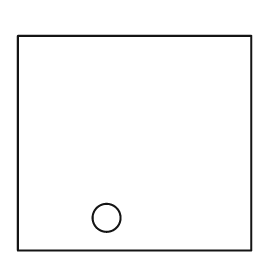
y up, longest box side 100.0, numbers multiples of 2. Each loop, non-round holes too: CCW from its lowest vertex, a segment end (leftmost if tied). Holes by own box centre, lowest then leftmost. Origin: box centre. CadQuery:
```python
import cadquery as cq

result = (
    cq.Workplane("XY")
    .moveTo(-50.0, -46.0)
    .lineTo(50.0, -46.0)
    .lineTo(50.0, 46.0)
    .lineTo(-50.0, 46.0)
    .close()
    .moveTo(-12.0, -32.0)
    .circle(6.0)
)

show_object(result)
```